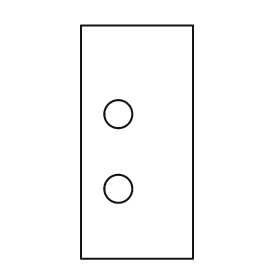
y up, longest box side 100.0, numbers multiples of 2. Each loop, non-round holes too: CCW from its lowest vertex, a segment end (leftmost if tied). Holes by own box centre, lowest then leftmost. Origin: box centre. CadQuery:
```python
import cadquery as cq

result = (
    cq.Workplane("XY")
    .moveTo(-24.0, -50.0)
    .lineTo(24.0, -50.0)
    .lineTo(24.0, 50.0)
    .lineTo(-24.0, 50.0)
    .close()
    .moveTo(-8.0, -20.0)
    .circle(6.0)
    .moveTo(-8.0, 12.0)
    .circle(6.0)
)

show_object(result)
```